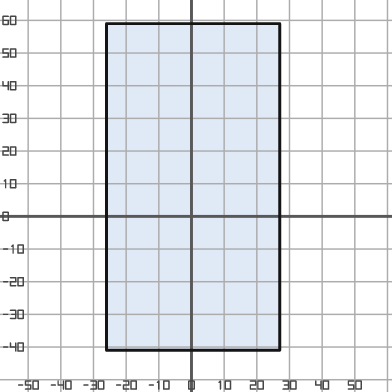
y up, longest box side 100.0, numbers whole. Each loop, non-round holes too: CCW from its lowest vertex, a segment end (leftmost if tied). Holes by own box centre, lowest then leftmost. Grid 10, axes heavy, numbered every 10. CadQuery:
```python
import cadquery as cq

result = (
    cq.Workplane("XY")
    .moveTo(-26.0, -41.0)
    .lineTo(27.0, -41.0)
    .lineTo(27.0, 59.0)
    .lineTo(-26.0, 59.0)
    .close()
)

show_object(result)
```